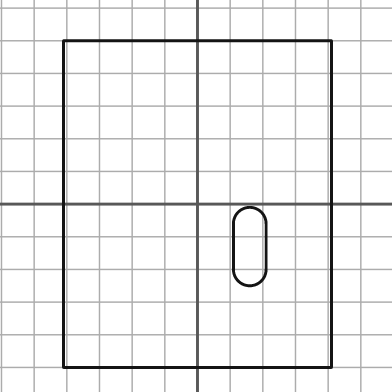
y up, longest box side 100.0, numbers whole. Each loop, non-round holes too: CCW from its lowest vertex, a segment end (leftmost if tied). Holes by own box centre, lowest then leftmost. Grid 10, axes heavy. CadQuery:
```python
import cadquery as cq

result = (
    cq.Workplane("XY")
    .moveTo(-41.0, -50.0)
    .lineTo(41.0, -50.0)
    .lineTo(41.0, 50.0)
    .lineTo(-41.0, 50.0)
    .close()
    .moveTo(11.0, -20.0)
    .threePointArc((16.0, -25.0), (21.0, -20.0))
    .lineTo(21.0, -6.0)
    .threePointArc((16.0, -1.0), (11.0, -6.0))
    .close()
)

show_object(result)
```